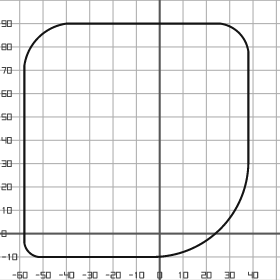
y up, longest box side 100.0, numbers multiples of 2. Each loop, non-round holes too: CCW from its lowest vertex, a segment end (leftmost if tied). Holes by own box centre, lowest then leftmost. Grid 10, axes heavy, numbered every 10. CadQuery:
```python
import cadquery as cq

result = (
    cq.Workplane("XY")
    .moveTo(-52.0, -10.0)
    .lineTo(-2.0, -10.0)
    .threePointArc((26.0, 2.0), (38.0, 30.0))
    .lineTo(38.0, 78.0)
    .threePointArc((34.0, 86.0), (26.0, 90.0))
    .lineTo(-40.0, 90.0)
    .threePointArc((-52.0, 84.0), (-58.0, 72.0))
    .lineTo(-58.0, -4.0)
    .threePointArc((-56.0, -8.0), (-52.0, -10.0))
    .close()
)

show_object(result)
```